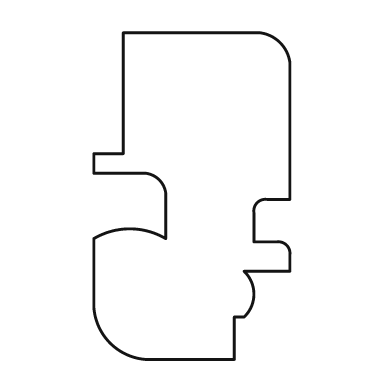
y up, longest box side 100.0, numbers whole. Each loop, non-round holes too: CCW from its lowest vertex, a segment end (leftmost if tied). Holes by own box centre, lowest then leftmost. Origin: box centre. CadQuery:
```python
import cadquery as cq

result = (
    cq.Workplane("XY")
    .moveTo(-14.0, -50.0)
    .lineTo(13.0, -50.0)
    .lineTo(13.0, -37.0)
    .lineTo(16.0, -37.0)
    .threePointArc((19.0, -30.0), (16.0, -23.0))
    .lineTo(30.0, -23.0)
    .lineTo(30.0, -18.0)
    .threePointArc((29.0, -15.0), (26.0, -14.0))
    .lineTo(19.0, -14.0)
    .lineTo(19.0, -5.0)
    .threePointArc((20.0, -2.0), (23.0, -1.0))
    .lineTo(30.0, -1.0)
    .lineTo(30.0, 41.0)
    .threePointArc((27.0, 47.0), (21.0, 50.0))
    .lineTo(-21.0, 50.0)
    .lineTo(-21.0, 13.0)
    .lineTo(-30.0, 13.0)
    .lineTo(-30.0, 7.0)
    .lineTo(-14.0, 7.0)
    .threePointArc((-10.0, 5.0), (-8.0, 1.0))
    .lineTo(-8.0, -13.0)
    .threePointArc((-19.0, -10.0), (-30.0, -13.0))
    .lineTo(-30.0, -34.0)
    .threePointArc((-25.0, -45.0), (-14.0, -50.0))
    .close()
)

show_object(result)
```